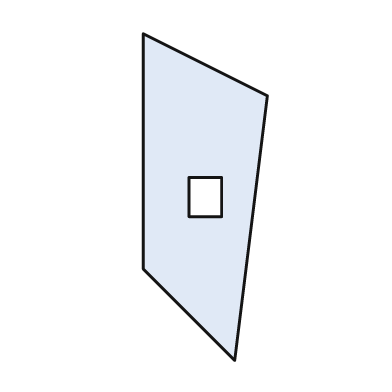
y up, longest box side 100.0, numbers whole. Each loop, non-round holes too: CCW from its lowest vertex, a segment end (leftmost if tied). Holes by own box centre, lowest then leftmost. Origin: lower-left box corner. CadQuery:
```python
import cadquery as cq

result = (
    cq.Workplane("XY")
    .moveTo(28.0, 0.0)
    .lineTo(38.0, 81.0)
    .lineTo(0.0, 100.0)
    .lineTo(0.0, 28.0)
    .close()
    .moveTo(14.0, 44.0)
    .lineTo(24.0, 44.0)
    .lineTo(24.0, 56.0)
    .lineTo(14.0, 56.0)
    .close()
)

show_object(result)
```